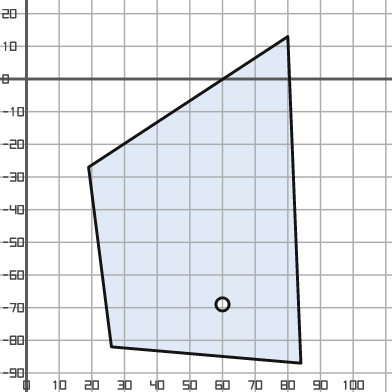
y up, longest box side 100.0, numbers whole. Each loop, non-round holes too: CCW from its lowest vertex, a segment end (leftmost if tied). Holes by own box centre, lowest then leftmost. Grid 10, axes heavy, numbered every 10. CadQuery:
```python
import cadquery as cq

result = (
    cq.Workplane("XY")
    .moveTo(84.0, -87.0)
    .lineTo(80.0, 13.0)
    .lineTo(19.0, -27.0)
    .lineTo(26.0, -82.0)
    .close()
    .moveTo(60.0, -69.0)
    .circle(2.0)
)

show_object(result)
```